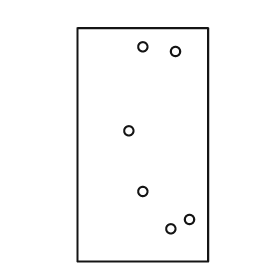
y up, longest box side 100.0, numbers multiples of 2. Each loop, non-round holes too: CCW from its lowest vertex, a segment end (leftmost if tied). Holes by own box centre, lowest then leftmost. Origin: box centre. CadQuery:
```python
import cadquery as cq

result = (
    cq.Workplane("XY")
    .moveTo(-28.0, -50.0)
    .lineTo(28.0, -50.0)
    .lineTo(28.0, 50.0)
    .lineTo(-28.0, 50.0)
    .close()
    .moveTo(12.0, -36.0)
    .circle(2.0)
    .moveTo(20.0, -32.0)
    .circle(2.0)
    .moveTo(0.0, -20.0)
    .circle(2.0)
    .moveTo(-6.0, 6.0)
    .circle(2.0)
    .moveTo(14.0, 40.0)
    .circle(2.0)
    .moveTo(0.0, 42.0)
    .circle(2.0)
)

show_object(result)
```